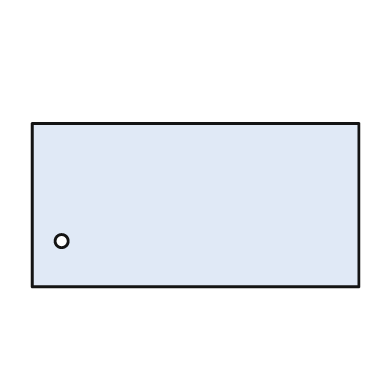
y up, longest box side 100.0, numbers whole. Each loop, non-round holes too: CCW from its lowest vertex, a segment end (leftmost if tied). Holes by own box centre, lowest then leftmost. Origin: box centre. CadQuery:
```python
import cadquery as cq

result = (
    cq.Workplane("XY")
    .moveTo(-50.0, -25.0)
    .lineTo(50.0, -25.0)
    .lineTo(50.0, 25.0)
    .lineTo(-50.0, 25.0)
    .close()
    .moveTo(-41.0, -11.0)
    .circle(2.0)
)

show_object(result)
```